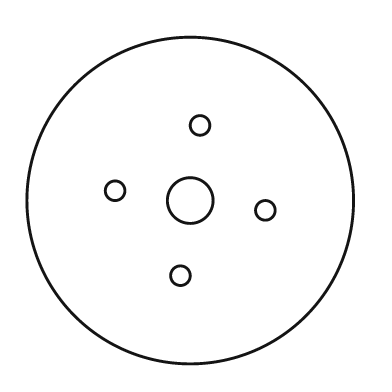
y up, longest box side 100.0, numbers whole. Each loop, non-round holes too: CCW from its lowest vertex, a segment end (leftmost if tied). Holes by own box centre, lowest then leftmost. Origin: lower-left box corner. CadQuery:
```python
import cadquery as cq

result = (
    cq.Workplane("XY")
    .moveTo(50.0, 50.0)
    .circle(50.0)
    .moveTo(47.0, 27.0)
    .circle(3.0)
    .moveTo(73.0, 47.0)
    .circle(3.0)
    .moveTo(50.0, 50.0)
    .circle(7.0)
    .moveTo(27.0, 53.0)
    .circle(3.0)
    .moveTo(53.0, 73.0)
    .circle(3.0)
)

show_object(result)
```